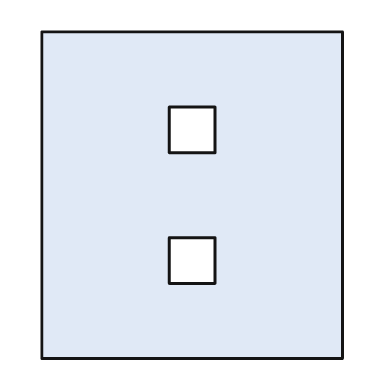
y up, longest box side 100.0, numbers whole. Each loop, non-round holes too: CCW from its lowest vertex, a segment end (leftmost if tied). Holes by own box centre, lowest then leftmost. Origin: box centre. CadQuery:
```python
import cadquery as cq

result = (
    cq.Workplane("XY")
    .moveTo(-46.0, -50.0)
    .lineTo(46.0, -50.0)
    .lineTo(46.0, 50.0)
    .lineTo(-46.0, 50.0)
    .close()
    .moveTo(-7.0, -27.0)
    .lineTo(7.0, -27.0)
    .lineTo(7.0, -13.0)
    .lineTo(-7.0, -13.0)
    .close()
    .moveTo(-7.0, 13.0)
    .lineTo(7.0, 13.0)
    .lineTo(7.0, 27.0)
    .lineTo(-7.0, 27.0)
    .close()
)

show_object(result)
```